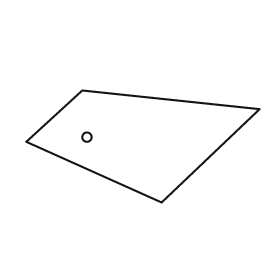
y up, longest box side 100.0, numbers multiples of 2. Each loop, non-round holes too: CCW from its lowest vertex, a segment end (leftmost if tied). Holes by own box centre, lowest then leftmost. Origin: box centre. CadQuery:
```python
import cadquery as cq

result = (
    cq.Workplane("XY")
    .moveTo(8.0, -24.0)
    .lineTo(50.0, 16.0)
    .lineTo(-26.0, 24.0)
    .lineTo(-50.0, 2.0)
    .close()
    .moveTo(-24.0, 4.0)
    .circle(2.0)
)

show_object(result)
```